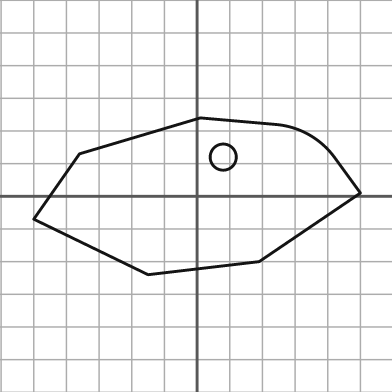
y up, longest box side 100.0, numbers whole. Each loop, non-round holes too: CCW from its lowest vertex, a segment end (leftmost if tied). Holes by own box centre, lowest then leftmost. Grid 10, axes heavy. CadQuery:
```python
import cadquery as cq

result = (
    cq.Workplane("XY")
    .moveTo(-15.0, -24.0)
    .lineTo(19.0, -20.0)
    .lineTo(50.0, 1.0)
    .lineTo(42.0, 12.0)
    .threePointArc((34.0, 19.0), (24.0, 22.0))
    .lineTo(1.0, 24.0)
    .lineTo(-36.0, 13.0)
    .lineTo(-50.0, -7.0)
    .close()
    .moveTo(8.0, 12.0)
    .circle(4.0)
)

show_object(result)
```